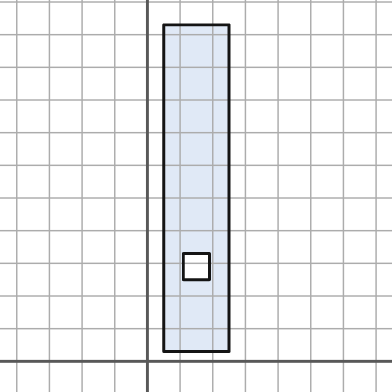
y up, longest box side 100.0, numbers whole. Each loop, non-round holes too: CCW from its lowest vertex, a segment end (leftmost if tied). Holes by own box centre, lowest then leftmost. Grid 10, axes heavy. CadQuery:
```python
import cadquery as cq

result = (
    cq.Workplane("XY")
    .moveTo(5.0, 3.0)
    .lineTo(25.0, 3.0)
    .lineTo(25.0, 103.0)
    .lineTo(5.0, 103.0)
    .close()
    .moveTo(11.0, 25.0)
    .lineTo(19.0, 25.0)
    .lineTo(19.0, 33.0)
    .lineTo(11.0, 33.0)
    .close()
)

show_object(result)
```